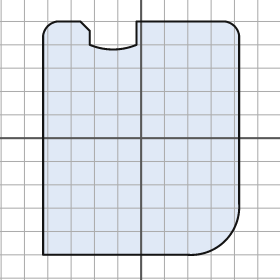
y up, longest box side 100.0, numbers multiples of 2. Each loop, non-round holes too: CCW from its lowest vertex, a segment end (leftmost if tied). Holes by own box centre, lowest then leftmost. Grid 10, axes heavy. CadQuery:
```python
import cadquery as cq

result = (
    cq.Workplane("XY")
    .moveTo(-42.0, -50.0)
    .lineTo(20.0, -50.0)
    .threePointArc((36.0, -44.0), (42.0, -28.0))
    .lineTo(42.0, 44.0)
    .threePointArc((40.0, 48.0), (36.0, 50.0))
    .lineTo(-2.0, 50.0)
    .lineTo(-2.0, 40.0)
    .threePointArc((-12.0, 38.0), (-22.0, 40.0))
    .lineTo(-22.0, 46.0)
    .lineTo(-26.0, 50.0)
    .lineTo(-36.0, 50.0)
    .threePointArc((-40.0, 48.0), (-42.0, 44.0))
    .close()
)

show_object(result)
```